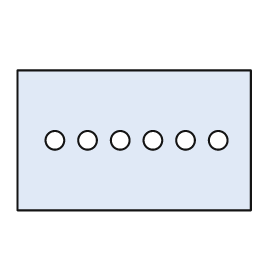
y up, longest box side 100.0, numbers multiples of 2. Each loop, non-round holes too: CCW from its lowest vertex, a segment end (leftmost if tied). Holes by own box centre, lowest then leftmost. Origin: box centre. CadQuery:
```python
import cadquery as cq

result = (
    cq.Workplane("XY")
    .moveTo(-50.0, -30.0)
    .lineTo(50.0, -30.0)
    .lineTo(50.0, 30.0)
    .lineTo(-50.0, 30.0)
    .close()
    .moveTo(-34.0, 0.0)
    .circle(4.0)
    .moveTo(-20.0, 0.0)
    .circle(4.0)
    .moveTo(-6.0, 0.0)
    .circle(4.0)
    .moveTo(8.0, 0.0)
    .circle(4.0)
    .moveTo(22.0, 0.0)
    .circle(4.0)
    .moveTo(36.0, 0.0)
    .circle(4.0)
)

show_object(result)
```